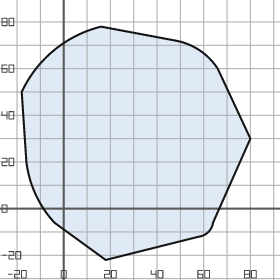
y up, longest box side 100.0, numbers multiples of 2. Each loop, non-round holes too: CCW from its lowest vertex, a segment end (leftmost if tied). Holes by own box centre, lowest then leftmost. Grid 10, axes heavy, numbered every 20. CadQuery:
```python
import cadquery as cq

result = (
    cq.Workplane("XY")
    .moveTo(18.0, -22.0)
    .lineTo(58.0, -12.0)
    .threePointArc((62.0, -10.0), (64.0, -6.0))
    .lineTo(80.0, 30.0)
    .lineTo(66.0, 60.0)
    .threePointArc((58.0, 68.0), (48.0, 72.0))
    .lineTo(16.0, 78.0)
    .threePointArc((-4.0, 68.0), (-18.0, 50.0))
    .lineTo(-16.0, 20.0)
    .threePointArc((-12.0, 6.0), (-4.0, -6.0))
    .close()
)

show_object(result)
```